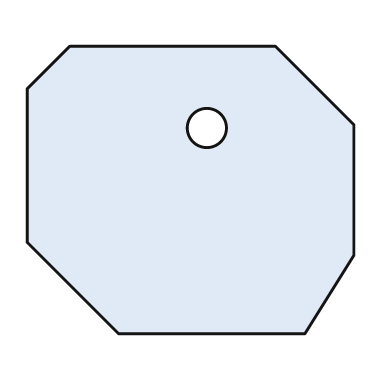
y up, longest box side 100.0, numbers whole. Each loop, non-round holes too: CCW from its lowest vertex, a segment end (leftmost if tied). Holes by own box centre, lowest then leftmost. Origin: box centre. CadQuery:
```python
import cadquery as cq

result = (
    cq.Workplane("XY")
    .moveTo(-22.0, -44.0)
    .lineTo(35.0, -44.0)
    .lineTo(50.0, -20.0)
    .lineTo(50.0, 20.0)
    .lineTo(26.0, 44.0)
    .lineTo(-37.0, 44.0)
    .lineTo(-50.0, 31.0)
    .lineTo(-50.0, -16.0)
    .close()
    .moveTo(5.0, 19.0)
    .circle(6.0)
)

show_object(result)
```